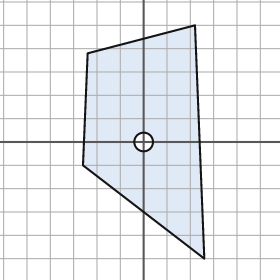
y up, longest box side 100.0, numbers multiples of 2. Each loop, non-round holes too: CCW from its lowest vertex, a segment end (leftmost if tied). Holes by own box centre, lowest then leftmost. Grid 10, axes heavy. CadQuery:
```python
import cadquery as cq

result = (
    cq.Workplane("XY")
    .moveTo(26.0, -50.0)
    .lineTo(22.0, 50.0)
    .lineTo(-24.0, 38.0)
    .lineTo(-26.0, -10.0)
    .close()
    .moveTo(0.0, 0.0)
    .circle(4.0)
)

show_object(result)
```